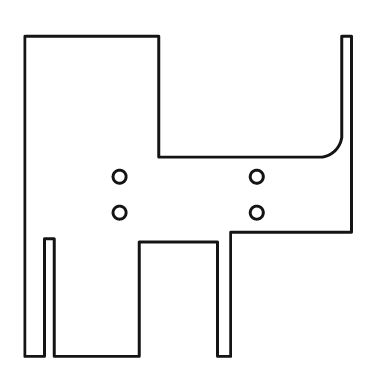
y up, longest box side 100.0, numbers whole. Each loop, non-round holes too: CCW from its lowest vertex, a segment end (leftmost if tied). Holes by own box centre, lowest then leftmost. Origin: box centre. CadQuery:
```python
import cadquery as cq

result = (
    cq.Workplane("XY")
    .moveTo(-50.0, -49.0)
    .lineTo(-44.0, -49.0)
    .lineTo(-44.0, -13.0)
    .lineTo(-41.0, -13.0)
    .lineTo(-41.0, -49.0)
    .lineTo(-15.0, -49.0)
    .lineTo(-15.0, -14.0)
    .lineTo(9.0, -14.0)
    .lineTo(9.0, -49.0)
    .lineTo(13.0, -49.0)
    .lineTo(13.0, -11.0)
    .lineTo(50.0, -11.0)
    .lineTo(50.0, 49.0)
    .lineTo(47.0, 49.0)
    .lineTo(47.0, 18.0)
    .threePointArc((45.0, 14.0), (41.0, 12.0))
    .lineTo(-9.0, 12.0)
    .lineTo(-9.0, 49.0)
    .lineTo(-50.0, 49.0)
    .close()
    .moveTo(-21.0, -5.0)
    .circle(2.0)
    .moveTo(21.0, -5.0)
    .circle(2.0)
    .moveTo(-21.0, 6.0)
    .circle(2.0)
    .moveTo(21.0, 6.0)
    .circle(2.0)
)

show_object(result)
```